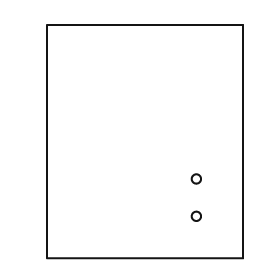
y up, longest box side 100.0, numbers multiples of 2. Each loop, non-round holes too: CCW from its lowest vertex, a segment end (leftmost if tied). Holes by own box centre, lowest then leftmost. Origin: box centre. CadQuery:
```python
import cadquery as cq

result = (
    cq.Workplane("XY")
    .moveTo(-42.0, -50.0)
    .lineTo(42.0, -50.0)
    .lineTo(42.0, 50.0)
    .lineTo(-42.0, 50.0)
    .close()
    .moveTo(22.0, -32.0)
    .circle(2.0)
    .moveTo(22.0, -16.0)
    .circle(2.0)
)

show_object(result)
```